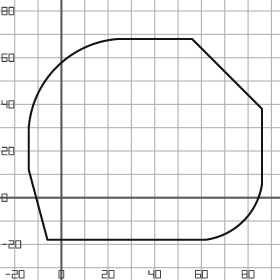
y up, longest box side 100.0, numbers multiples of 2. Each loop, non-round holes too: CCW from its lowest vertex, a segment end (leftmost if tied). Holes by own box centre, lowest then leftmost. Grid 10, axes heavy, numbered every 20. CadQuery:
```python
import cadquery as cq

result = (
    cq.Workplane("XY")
    .moveTo(-6.0, -18.0)
    .lineTo(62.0, -18.0)
    .threePointArc((78.0, -10.0), (86.0, 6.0))
    .lineTo(86.0, 38.0)
    .lineTo(56.0, 68.0)
    .lineTo(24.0, 68.0)
    .threePointArc((-2.0, 56.0), (-14.0, 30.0))
    .lineTo(-14.0, 12.0)
    .close()
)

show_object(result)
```